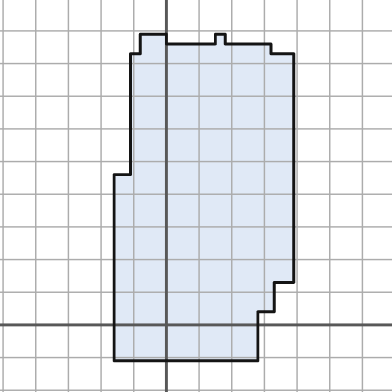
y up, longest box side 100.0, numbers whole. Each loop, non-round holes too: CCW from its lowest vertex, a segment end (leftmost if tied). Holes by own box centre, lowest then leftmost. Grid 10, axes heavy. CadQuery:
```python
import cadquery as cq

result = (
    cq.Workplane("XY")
    .moveTo(-16.0, -11.0)
    .lineTo(28.0, -11.0)
    .lineTo(28.0, 4.0)
    .lineTo(33.0, 4.0)
    .lineTo(33.0, 13.0)
    .lineTo(39.0, 13.0)
    .lineTo(39.0, 83.0)
    .lineTo(32.0, 83.0)
    .lineTo(32.0, 86.0)
    .lineTo(18.0, 86.0)
    .lineTo(18.0, 89.0)
    .lineTo(15.0, 89.0)
    .lineTo(15.0, 86.0)
    .lineTo(0.0, 86.0)
    .lineTo(0.0, 89.0)
    .lineTo(-8.0, 89.0)
    .lineTo(-8.0, 83.0)
    .lineTo(-11.0, 83.0)
    .lineTo(-11.0, 46.0)
    .lineTo(-16.0, 46.0)
    .close()
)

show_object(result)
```